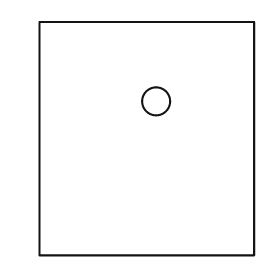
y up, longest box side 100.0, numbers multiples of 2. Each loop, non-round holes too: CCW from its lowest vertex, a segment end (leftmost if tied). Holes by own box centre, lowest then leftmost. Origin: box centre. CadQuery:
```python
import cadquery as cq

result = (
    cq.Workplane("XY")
    .moveTo(-46.0, -50.0)
    .lineTo(46.0, -50.0)
    .lineTo(46.0, 50.0)
    .lineTo(-46.0, 50.0)
    .close()
    .moveTo(4.0, 16.0)
    .circle(6.0)
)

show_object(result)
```